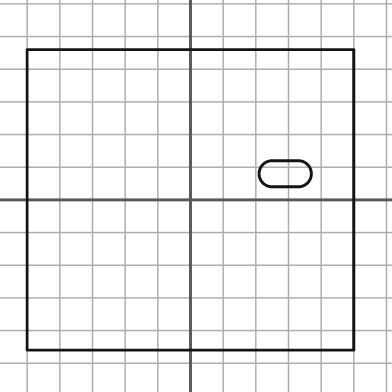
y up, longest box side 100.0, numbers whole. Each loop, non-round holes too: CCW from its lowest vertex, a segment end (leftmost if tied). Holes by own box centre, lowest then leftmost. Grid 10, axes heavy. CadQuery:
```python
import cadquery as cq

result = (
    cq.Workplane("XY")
    .moveTo(-50.0, -46.0)
    .lineTo(50.0, -46.0)
    .lineTo(50.0, 46.0)
    .lineTo(-50.0, 46.0)
    .close()
    .moveTo(25.0, 4.0)
    .lineTo(33.0, 4.0)
    .threePointArc((37.0, 8.0), (33.0, 12.0))
    .lineTo(25.0, 12.0)
    .threePointArc((21.0, 8.0), (25.0, 4.0))
    .close()
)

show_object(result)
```